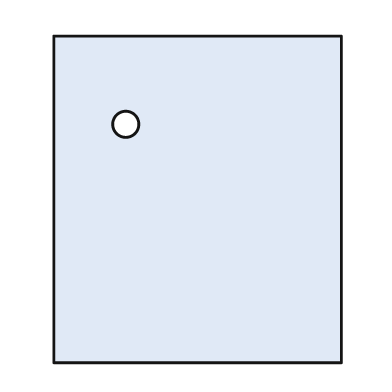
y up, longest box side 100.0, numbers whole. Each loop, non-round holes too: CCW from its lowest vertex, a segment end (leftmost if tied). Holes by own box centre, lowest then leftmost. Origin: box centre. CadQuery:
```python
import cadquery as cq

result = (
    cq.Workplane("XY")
    .moveTo(-44.0, -50.0)
    .lineTo(44.0, -50.0)
    .lineTo(44.0, 50.0)
    .lineTo(-44.0, 50.0)
    .close()
    .moveTo(-22.0, 23.0)
    .circle(4.0)
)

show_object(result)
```